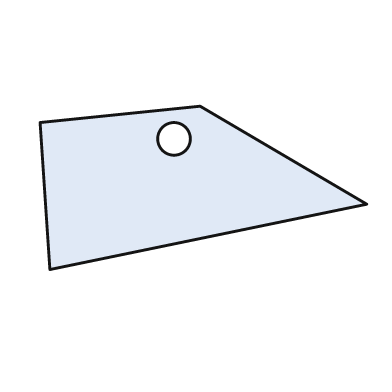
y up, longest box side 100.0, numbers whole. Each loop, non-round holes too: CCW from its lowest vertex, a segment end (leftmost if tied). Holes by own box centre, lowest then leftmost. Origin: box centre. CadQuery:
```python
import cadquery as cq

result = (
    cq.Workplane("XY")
    .moveTo(-47.0, -25.0)
    .lineTo(50.0, -5.0)
    .lineTo(-1.0, 25.0)
    .lineTo(-50.0, 20.0)
    .close()
    .moveTo(-9.0, 15.0)
    .circle(5.0)
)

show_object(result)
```